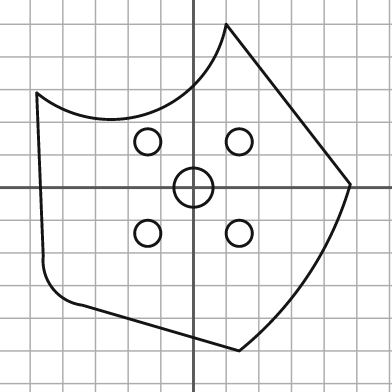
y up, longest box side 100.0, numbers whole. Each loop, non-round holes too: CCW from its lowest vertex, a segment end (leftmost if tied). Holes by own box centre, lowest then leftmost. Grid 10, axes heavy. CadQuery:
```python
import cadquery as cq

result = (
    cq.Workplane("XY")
    .moveTo(14.0, -50.0)
    .threePointArc((35.0, -27.0), (48.0, 1.0))
    .lineTo(10.0, 50.0)
    .threePointArc((-13.0, 23.0), (-48.0, 29.0))
    .lineTo(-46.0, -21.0)
    .threePointArc((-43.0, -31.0), (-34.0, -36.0))
    .close()
    .moveTo(-14.0, -14.0)
    .circle(4.0)
    .moveTo(14.0, -14.0)
    .circle(4.0)
    .moveTo(0.0, 0.0)
    .circle(6.0)
    .moveTo(-14.0, 14.0)
    .circle(4.0)
    .moveTo(14.0, 14.0)
    .circle(4.0)
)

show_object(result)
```